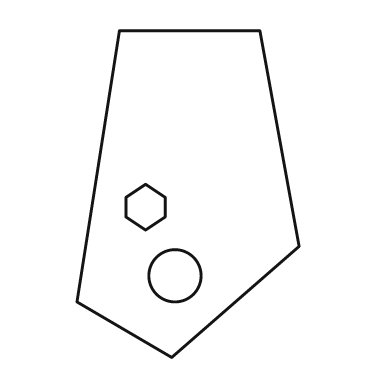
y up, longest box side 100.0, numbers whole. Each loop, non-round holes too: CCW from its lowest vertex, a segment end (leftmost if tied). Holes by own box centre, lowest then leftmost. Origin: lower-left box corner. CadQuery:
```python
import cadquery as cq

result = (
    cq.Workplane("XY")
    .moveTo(29.0, 0.0)
    .lineTo(68.0, 34.0)
    .lineTo(56.0, 100.0)
    .lineTo(13.0, 100.0)
    .lineTo(0.0, 17.0)
    .close()
    .moveTo(30.0, 25.0)
    .circle(8.0)
    .moveTo(21.0, 39.0)
    .lineTo(27.0, 43.0)
    .lineTo(27.0, 49.0)
    .lineTo(21.0, 53.0)
    .lineTo(15.0, 49.0)
    .lineTo(15.0, 43.0)
    .close()
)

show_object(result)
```